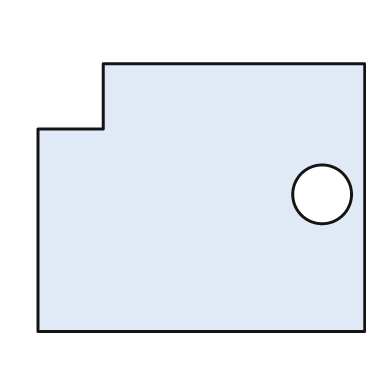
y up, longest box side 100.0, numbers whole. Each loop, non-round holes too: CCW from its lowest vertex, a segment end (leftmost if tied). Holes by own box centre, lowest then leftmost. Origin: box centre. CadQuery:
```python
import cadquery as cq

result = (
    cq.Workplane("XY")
    .moveTo(-50.0, -41.0)
    .lineTo(50.0, -41.0)
    .lineTo(50.0, 41.0)
    .lineTo(-30.0, 41.0)
    .lineTo(-30.0, 21.0)
    .lineTo(-50.0, 21.0)
    .close()
    .moveTo(37.0, 1.0)
    .circle(9.0)
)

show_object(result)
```